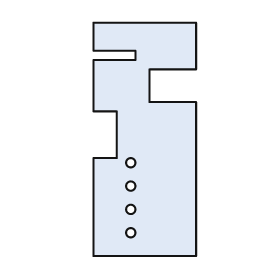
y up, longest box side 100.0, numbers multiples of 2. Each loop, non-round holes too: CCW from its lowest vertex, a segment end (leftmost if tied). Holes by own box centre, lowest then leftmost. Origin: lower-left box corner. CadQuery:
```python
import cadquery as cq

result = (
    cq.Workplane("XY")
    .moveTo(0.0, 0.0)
    .lineTo(44.0, 0.0)
    .lineTo(44.0, 66.0)
    .lineTo(24.0, 66.0)
    .lineTo(24.0, 80.0)
    .lineTo(44.0, 80.0)
    .lineTo(44.0, 100.0)
    .lineTo(0.0, 100.0)
    .lineTo(0.0, 88.0)
    .lineTo(18.0, 88.0)
    .lineTo(18.0, 84.0)
    .lineTo(0.0, 84.0)
    .lineTo(0.0, 62.0)
    .lineTo(10.0, 62.0)
    .lineTo(10.0, 42.0)
    .lineTo(0.0, 42.0)
    .close()
    .moveTo(16.0, 10.0)
    .circle(2.0)
    .moveTo(16.0, 20.0)
    .circle(2.0)
    .moveTo(16.0, 30.0)
    .circle(2.0)
    .moveTo(16.0, 40.0)
    .circle(2.0)
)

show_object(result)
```